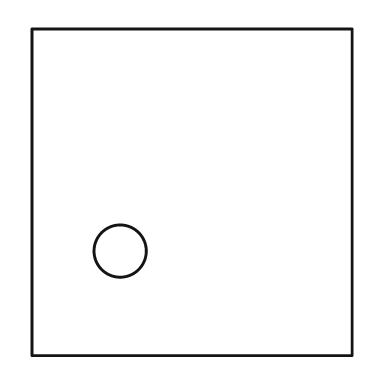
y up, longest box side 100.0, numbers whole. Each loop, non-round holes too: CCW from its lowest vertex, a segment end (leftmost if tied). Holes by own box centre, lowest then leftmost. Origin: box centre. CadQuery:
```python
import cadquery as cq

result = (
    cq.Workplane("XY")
    .moveTo(-49.0, -50.0)
    .lineTo(49.0, -50.0)
    .lineTo(49.0, 50.0)
    .lineTo(-49.0, 50.0)
    .close()
    .moveTo(-22.0, -18.0)
    .circle(8.0)
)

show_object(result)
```